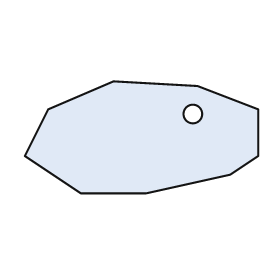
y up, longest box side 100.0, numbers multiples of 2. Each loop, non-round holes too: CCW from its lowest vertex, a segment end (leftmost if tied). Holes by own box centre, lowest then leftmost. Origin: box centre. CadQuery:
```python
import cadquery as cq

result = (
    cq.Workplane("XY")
    .moveTo(-26.0, -24.0)
    .lineTo(2.0, -24.0)
    .lineTo(38.0, -16.0)
    .lineTo(50.0, -8.0)
    .lineTo(50.0, 12.0)
    .lineTo(24.0, 22.0)
    .lineTo(-12.0, 24.0)
    .lineTo(-40.0, 12.0)
    .lineTo(-50.0, -8.0)
    .close()
    .moveTo(22.0, 10.0)
    .circle(4.0)
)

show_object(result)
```